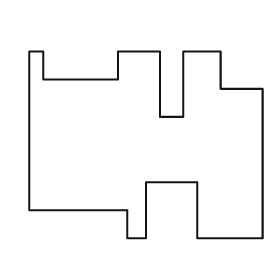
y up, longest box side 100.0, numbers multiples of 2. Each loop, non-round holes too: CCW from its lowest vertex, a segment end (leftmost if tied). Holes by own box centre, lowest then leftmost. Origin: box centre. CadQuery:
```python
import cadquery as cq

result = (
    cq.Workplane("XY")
    .moveTo(-8.0, -40.0)
    .lineTo(0.0, -40.0)
    .lineTo(0.0, -16.0)
    .lineTo(22.0, -16.0)
    .lineTo(22.0, -40.0)
    .lineTo(50.0, -40.0)
    .lineTo(50.0, 24.0)
    .lineTo(32.0, 24.0)
    .lineTo(32.0, 40.0)
    .lineTo(16.0, 40.0)
    .lineTo(16.0, 12.0)
    .lineTo(6.0, 12.0)
    .lineTo(6.0, 40.0)
    .lineTo(-12.0, 40.0)
    .lineTo(-12.0, 28.0)
    .lineTo(-44.0, 28.0)
    .lineTo(-44.0, 40.0)
    .lineTo(-50.0, 40.0)
    .lineTo(-50.0, -28.0)
    .lineTo(-8.0, -28.0)
    .close()
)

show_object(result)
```